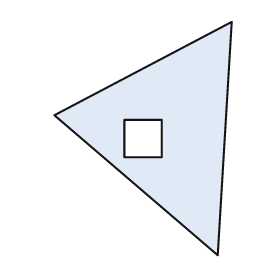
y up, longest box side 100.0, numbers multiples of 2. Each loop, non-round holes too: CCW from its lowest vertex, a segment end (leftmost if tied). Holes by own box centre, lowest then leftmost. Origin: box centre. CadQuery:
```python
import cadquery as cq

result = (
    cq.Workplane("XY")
    .moveTo(32.0, -50.0)
    .lineTo(38.0, 50.0)
    .lineTo(-38.0, 10.0)
    .close()
    .moveTo(-8.0, -8.0)
    .lineTo(8.0, -8.0)
    .lineTo(8.0, 8.0)
    .lineTo(-8.0, 8.0)
    .close()
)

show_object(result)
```